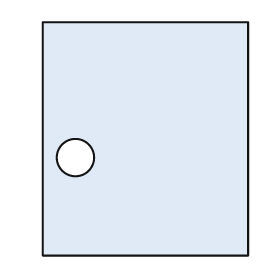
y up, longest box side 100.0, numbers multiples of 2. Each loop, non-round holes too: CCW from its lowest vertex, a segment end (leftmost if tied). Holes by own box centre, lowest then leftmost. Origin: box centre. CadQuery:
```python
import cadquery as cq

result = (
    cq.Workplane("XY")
    .moveTo(-44.0, -50.0)
    .lineTo(44.0, -50.0)
    .lineTo(44.0, 50.0)
    .lineTo(-44.0, 50.0)
    .close()
    .moveTo(-30.0, -8.0)
    .circle(8.0)
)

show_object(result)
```